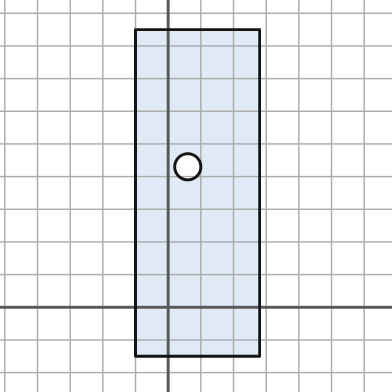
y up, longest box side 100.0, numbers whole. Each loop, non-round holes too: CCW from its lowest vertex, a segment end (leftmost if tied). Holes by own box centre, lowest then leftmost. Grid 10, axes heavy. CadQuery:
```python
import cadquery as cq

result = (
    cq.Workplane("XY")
    .moveTo(-10.0, -15.0)
    .lineTo(28.0, -15.0)
    .lineTo(28.0, 85.0)
    .lineTo(-10.0, 85.0)
    .close()
    .moveTo(6.0, 43.0)
    .circle(4.0)
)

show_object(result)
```